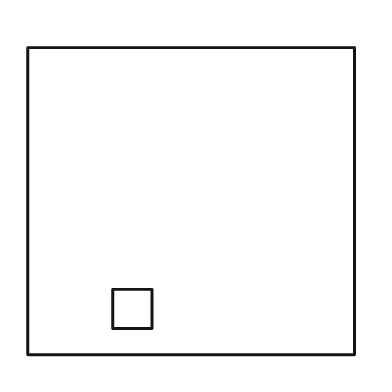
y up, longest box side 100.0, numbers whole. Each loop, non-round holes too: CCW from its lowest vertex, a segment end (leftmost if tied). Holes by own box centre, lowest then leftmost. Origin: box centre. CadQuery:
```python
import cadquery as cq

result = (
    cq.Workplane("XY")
    .moveTo(-50.0, -47.0)
    .lineTo(50.0, -47.0)
    .lineTo(50.0, 47.0)
    .lineTo(-50.0, 47.0)
    .close()
    .moveTo(-24.0, -39.0)
    .lineTo(-12.0, -39.0)
    .lineTo(-12.0, -27.0)
    .lineTo(-24.0, -27.0)
    .close()
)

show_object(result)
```